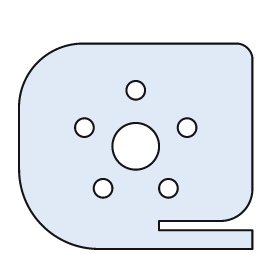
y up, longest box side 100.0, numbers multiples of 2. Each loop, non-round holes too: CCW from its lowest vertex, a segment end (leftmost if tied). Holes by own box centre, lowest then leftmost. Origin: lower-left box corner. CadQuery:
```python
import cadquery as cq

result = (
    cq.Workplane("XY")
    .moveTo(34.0, 0.0)
    .lineTo(100.0, 0.0)
    .lineTo(100.0, 8.0)
    .lineTo(60.0, 8.0)
    .lineTo(60.0, 12.0)
    .lineTo(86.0, 12.0)
    .threePointArc((96.0, 16.0), (100.0, 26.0))
    .lineTo(100.0, 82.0)
    .threePointArc((98.0, 86.0), (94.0, 88.0))
    .lineTo(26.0, 88.0)
    .threePointArc((8.0, 80.0), (0.0, 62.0))
    .lineTo(0.0, 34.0)
    .threePointArc((10.0, 10.0), (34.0, 0.0))
    .close()
    .moveTo(36.0, 26.0)
    .circle(4.0)
    .moveTo(64.0, 26.0)
    .circle(4.0)
    .moveTo(50.0, 44.0)
    .circle(10.0)
    .moveTo(28.0, 52.0)
    .circle(4.0)
    .moveTo(72.0, 52.0)
    .circle(4.0)
    .moveTo(50.0, 68.0)
    .circle(4.0)
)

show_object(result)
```